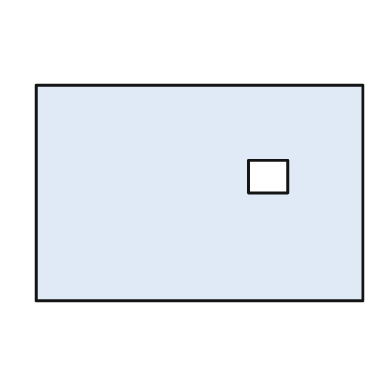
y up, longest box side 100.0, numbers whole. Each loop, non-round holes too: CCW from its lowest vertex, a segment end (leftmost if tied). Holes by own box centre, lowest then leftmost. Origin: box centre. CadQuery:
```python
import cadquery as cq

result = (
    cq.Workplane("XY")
    .moveTo(-50.0, -33.0)
    .lineTo(50.0, -33.0)
    .lineTo(50.0, 33.0)
    .lineTo(-50.0, 33.0)
    .close()
    .moveTo(15.0, 0.0)
    .lineTo(27.0, 0.0)
    .lineTo(27.0, 10.0)
    .lineTo(15.0, 10.0)
    .close()
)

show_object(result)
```